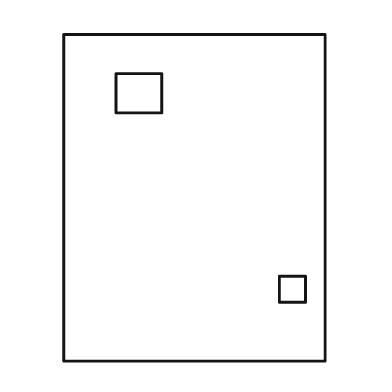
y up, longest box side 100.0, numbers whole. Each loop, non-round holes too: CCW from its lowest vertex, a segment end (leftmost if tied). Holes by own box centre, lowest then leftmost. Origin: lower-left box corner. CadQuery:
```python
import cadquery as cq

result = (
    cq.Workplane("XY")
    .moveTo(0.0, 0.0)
    .lineTo(80.0, 0.0)
    .lineTo(80.0, 100.0)
    .lineTo(0.0, 100.0)
    .close()
    .moveTo(66.0, 18.0)
    .lineTo(74.0, 18.0)
    .lineTo(74.0, 26.0)
    .lineTo(66.0, 26.0)
    .close()
    .moveTo(16.0, 76.0)
    .lineTo(30.0, 76.0)
    .lineTo(30.0, 88.0)
    .lineTo(16.0, 88.0)
    .close()
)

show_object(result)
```